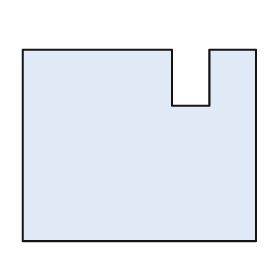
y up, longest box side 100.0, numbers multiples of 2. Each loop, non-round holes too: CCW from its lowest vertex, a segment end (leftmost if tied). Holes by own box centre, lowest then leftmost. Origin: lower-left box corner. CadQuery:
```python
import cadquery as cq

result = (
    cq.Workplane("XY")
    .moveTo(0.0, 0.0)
    .lineTo(100.0, 0.0)
    .lineTo(100.0, 82.0)
    .lineTo(80.0, 82.0)
    .lineTo(80.0, 58.0)
    .lineTo(64.0, 58.0)
    .lineTo(64.0, 82.0)
    .lineTo(0.0, 82.0)
    .close()
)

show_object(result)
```